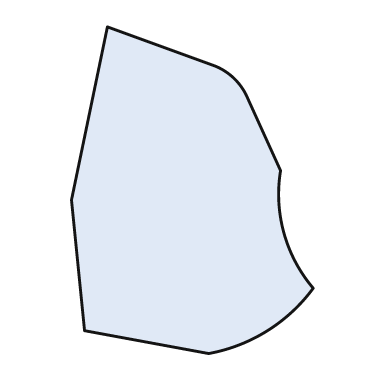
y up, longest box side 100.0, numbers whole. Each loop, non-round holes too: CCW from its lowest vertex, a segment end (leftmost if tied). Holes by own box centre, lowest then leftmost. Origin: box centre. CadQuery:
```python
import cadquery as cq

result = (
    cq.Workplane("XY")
    .moveTo(5.0, -50.0)
    .threePointArc((23.0, -43.0), (37.0, -30.0))
    .threePointArc((28.0, -13.0), (27.0, 6.0))
    .lineTo(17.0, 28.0)
    .threePointArc((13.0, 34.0), (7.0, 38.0))
    .lineTo(-26.0, 50.0)
    .lineTo(-37.0, -3.0)
    .lineTo(-33.0, -43.0)
    .close()
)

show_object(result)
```